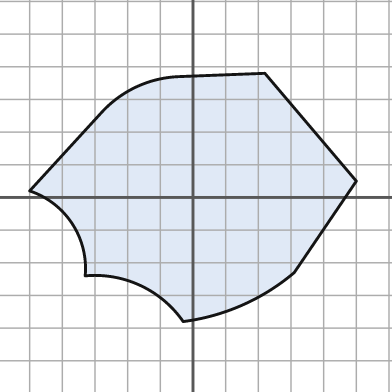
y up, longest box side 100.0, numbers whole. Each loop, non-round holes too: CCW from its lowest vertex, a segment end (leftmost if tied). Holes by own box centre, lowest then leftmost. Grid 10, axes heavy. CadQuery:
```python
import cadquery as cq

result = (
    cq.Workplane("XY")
    .moveTo(-3.0, -38.0)
    .threePointArc((15.0, -33.0), (31.0, -23.0))
    .lineTo(50.0, 5.0)
    .lineTo(22.0, 38.0)
    .lineTo(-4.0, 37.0)
    .threePointArc((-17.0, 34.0), (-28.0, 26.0))
    .lineTo(-50.0, 2.0)
    .threePointArc((-37.0, -8.0), (-33.0, -24.0))
    .threePointArc((-16.0, -27.0), (-3.0, -38.0))
    .close()
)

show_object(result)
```